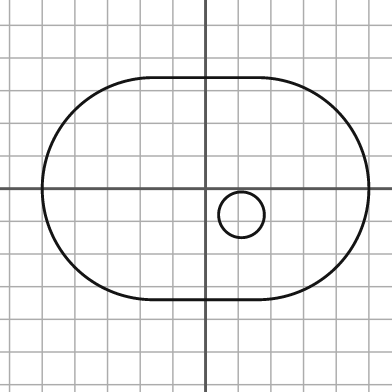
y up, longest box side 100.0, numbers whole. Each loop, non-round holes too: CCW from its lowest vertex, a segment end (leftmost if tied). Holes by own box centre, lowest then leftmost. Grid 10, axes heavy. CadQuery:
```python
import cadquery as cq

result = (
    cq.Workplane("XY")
    .moveTo(-16.0, -34.0)
    .lineTo(16.0, -34.0)
    .threePointArc((50.0, 0.0), (16.0, 34.0))
    .lineTo(-16.0, 34.0)
    .threePointArc((-50.0, 0.0), (-16.0, -34.0))
    .close()
    .moveTo(11.0, -8.0)
    .circle(7.0)
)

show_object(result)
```